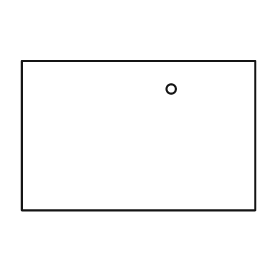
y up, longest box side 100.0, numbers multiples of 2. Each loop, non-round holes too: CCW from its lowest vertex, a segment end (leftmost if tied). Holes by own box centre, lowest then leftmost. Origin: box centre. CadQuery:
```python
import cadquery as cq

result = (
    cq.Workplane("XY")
    .moveTo(-50.0, -32.0)
    .lineTo(50.0, -32.0)
    .lineTo(50.0, 32.0)
    .lineTo(-50.0, 32.0)
    .close()
    .moveTo(14.0, 20.0)
    .circle(2.0)
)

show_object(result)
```